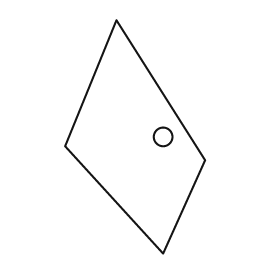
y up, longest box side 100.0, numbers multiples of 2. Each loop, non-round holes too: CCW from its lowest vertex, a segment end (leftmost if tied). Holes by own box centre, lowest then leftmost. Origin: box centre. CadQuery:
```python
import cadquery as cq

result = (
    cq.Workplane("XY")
    .moveTo(12.0, -50.0)
    .lineTo(30.0, -10.0)
    .lineTo(-8.0, 50.0)
    .lineTo(-30.0, -4.0)
    .close()
    .moveTo(12.0, 0.0)
    .circle(4.0)
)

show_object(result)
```